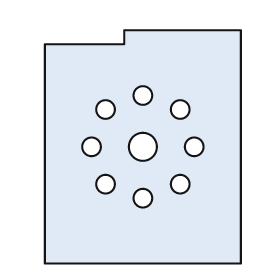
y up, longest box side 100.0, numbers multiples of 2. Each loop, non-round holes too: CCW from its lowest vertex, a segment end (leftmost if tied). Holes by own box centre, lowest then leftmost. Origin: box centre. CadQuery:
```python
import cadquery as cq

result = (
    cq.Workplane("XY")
    .moveTo(-42.0, -50.0)
    .lineTo(42.0, -50.0)
    .lineTo(42.0, 50.0)
    .lineTo(-8.0, 50.0)
    .lineTo(-8.0, 44.0)
    .lineTo(-42.0, 44.0)
    .close()
    .moveTo(0.0, -22.0)
    .circle(4.0)
    .moveTo(-16.0, -16.0)
    .circle(4.0)
    .moveTo(16.0, -16.0)
    .circle(4.0)
    .moveTo(-22.0, 0.0)
    .circle(4.0)
    .moveTo(0.0, 0.0)
    .circle(6.0)
    .moveTo(22.0, 0.0)
    .circle(4.0)
    .moveTo(-16.0, 16.0)
    .circle(4.0)
    .moveTo(16.0, 16.0)
    .circle(4.0)
    .moveTo(0.0, 22.0)
    .circle(4.0)
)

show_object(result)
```